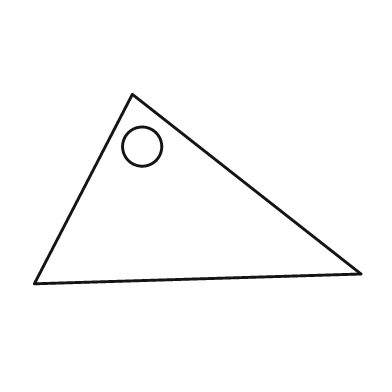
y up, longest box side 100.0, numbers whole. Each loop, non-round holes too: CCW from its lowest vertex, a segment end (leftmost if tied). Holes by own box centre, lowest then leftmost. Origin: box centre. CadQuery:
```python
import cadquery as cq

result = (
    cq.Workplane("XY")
    .moveTo(-50.0, -29.0)
    .lineTo(50.0, -26.0)
    .lineTo(-20.0, 29.0)
    .close()
    .moveTo(-17.0, 13.0)
    .circle(6.0)
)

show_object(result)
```